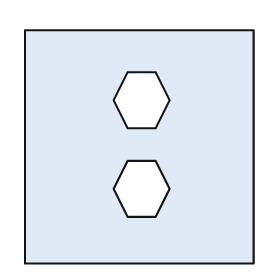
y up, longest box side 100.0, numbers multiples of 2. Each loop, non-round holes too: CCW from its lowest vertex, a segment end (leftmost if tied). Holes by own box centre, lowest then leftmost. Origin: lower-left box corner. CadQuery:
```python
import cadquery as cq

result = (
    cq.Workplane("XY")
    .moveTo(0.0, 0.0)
    .lineTo(98.0, 0.0)
    .lineTo(98.0, 100.0)
    .lineTo(0.0, 100.0)
    .close()
    .moveTo(44.0, 20.0)
    .lineTo(56.0, 20.0)
    .lineTo(62.0, 32.0)
    .lineTo(56.0, 44.0)
    .lineTo(44.0, 44.0)
    .lineTo(38.0, 32.0)
    .close()
    .moveTo(44.0, 58.0)
    .lineTo(56.0, 58.0)
    .lineTo(62.0, 70.0)
    .lineTo(56.0, 82.0)
    .lineTo(44.0, 82.0)
    .lineTo(38.0, 70.0)
    .close()
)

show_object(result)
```